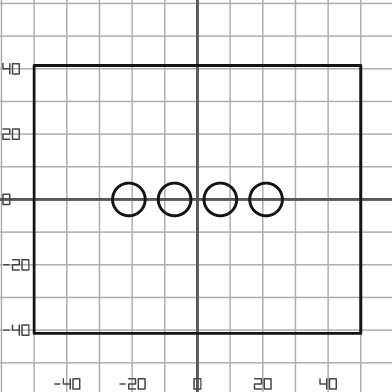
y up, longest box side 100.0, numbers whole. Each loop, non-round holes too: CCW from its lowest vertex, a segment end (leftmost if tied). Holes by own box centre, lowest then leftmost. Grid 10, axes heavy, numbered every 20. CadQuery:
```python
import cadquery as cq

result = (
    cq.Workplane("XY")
    .moveTo(-50.0, -41.0)
    .lineTo(50.0, -41.0)
    .lineTo(50.0, 41.0)
    .lineTo(-50.0, 41.0)
    .close()
    .moveTo(-21.0, 0.0)
    .circle(5.0)
    .moveTo(-7.0, 0.0)
    .circle(5.0)
    .moveTo(7.0, 0.0)
    .circle(5.0)
    .moveTo(21.0, 0.0)
    .circle(5.0)
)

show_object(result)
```